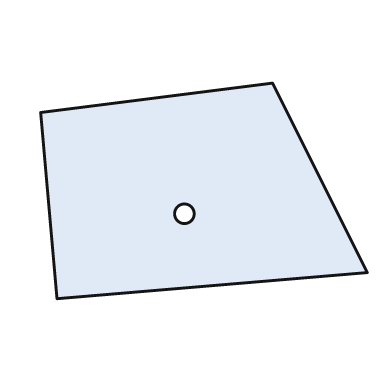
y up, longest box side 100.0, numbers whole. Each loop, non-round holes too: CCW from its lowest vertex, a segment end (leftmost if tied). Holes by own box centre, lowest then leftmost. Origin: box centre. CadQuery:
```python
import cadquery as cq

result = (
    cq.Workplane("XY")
    .moveTo(-45.0, -33.0)
    .lineTo(50.0, -25.0)
    .lineTo(21.0, 33.0)
    .lineTo(-50.0, 24.0)
    .close()
    .moveTo(-6.0, -7.0)
    .circle(3.0)
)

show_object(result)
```